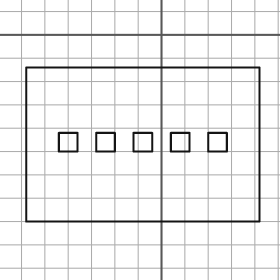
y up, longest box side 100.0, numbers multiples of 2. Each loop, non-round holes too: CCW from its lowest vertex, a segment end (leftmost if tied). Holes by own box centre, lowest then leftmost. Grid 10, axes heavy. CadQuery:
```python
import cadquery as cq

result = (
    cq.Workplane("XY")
    .moveTo(-58.0, -80.0)
    .lineTo(42.0, -80.0)
    .lineTo(42.0, -14.0)
    .lineTo(-58.0, -14.0)
    .close()
    .moveTo(-44.0, -50.0)
    .lineTo(-36.0, -50.0)
    .lineTo(-36.0, -42.0)
    .lineTo(-44.0, -42.0)
    .close()
    .moveTo(-28.0, -50.0)
    .lineTo(-20.0, -50.0)
    .lineTo(-20.0, -42.0)
    .lineTo(-28.0, -42.0)
    .close()
    .moveTo(-12.0, -50.0)
    .lineTo(-4.0, -50.0)
    .lineTo(-4.0, -42.0)
    .lineTo(-12.0, -42.0)
    .close()
    .moveTo(4.0, -50.0)
    .lineTo(12.0, -50.0)
    .lineTo(12.0, -42.0)
    .lineTo(4.0, -42.0)
    .close()
    .moveTo(20.0, -50.0)
    .lineTo(28.0, -50.0)
    .lineTo(28.0, -42.0)
    .lineTo(20.0, -42.0)
    .close()
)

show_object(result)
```